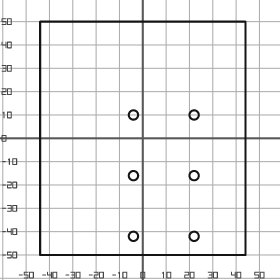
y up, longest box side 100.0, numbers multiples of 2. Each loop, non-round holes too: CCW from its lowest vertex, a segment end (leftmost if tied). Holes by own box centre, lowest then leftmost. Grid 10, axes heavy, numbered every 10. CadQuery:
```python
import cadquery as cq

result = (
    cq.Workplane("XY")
    .moveTo(-44.0, -50.0)
    .lineTo(44.0, -50.0)
    .lineTo(44.0, 50.0)
    .lineTo(-44.0, 50.0)
    .close()
    .moveTo(-4.0, -42.0)
    .circle(2.0)
    .moveTo(22.0, -42.0)
    .circle(2.0)
    .moveTo(-4.0, -16.0)
    .circle(2.0)
    .moveTo(22.0, -16.0)
    .circle(2.0)
    .moveTo(-4.0, 10.0)
    .circle(2.0)
    .moveTo(22.0, 10.0)
    .circle(2.0)
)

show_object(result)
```